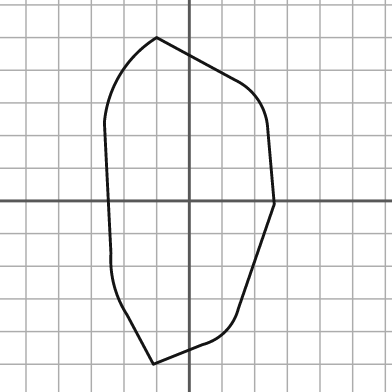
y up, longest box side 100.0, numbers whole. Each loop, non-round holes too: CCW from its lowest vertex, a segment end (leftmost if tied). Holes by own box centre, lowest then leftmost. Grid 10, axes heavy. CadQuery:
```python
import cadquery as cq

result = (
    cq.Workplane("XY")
    .moveTo(-11.0, -50.0)
    .lineTo(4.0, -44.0)
    .threePointArc((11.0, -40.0), (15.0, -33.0))
    .lineTo(26.0, -1.0)
    .lineTo(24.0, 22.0)
    .threePointArc((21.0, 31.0), (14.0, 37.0))
    .lineTo(-10.0, 50.0)
    .threePointArc((-21.0, 39.0), (-26.0, 24.0))
    .lineTo(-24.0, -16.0)
    .threePointArc((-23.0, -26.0), (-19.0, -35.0))
    .close()
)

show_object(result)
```